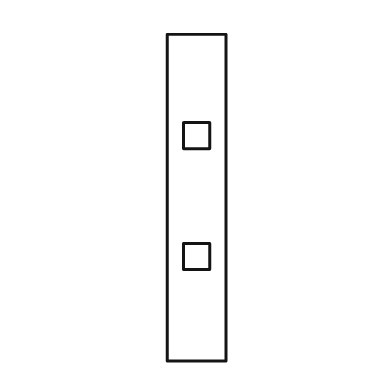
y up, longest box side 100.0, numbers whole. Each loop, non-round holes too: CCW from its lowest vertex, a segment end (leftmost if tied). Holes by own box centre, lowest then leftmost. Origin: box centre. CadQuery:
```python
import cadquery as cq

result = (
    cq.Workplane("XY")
    .moveTo(-9.0, -50.0)
    .lineTo(9.0, -50.0)
    .lineTo(9.0, 50.0)
    .lineTo(-9.0, 50.0)
    .close()
    .moveTo(-4.0, -22.0)
    .lineTo(4.0, -22.0)
    .lineTo(4.0, -14.0)
    .lineTo(-4.0, -14.0)
    .close()
    .moveTo(-4.0, 15.0)
    .lineTo(4.0, 15.0)
    .lineTo(4.0, 23.0)
    .lineTo(-4.0, 23.0)
    .close()
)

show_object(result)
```